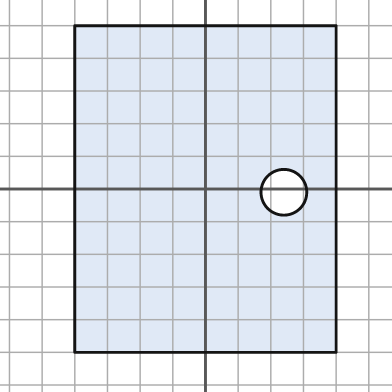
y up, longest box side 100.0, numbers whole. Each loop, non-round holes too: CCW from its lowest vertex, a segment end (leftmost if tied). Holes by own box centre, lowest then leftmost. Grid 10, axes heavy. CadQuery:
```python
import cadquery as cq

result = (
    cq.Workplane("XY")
    .moveTo(-40.0, -50.0)
    .lineTo(40.0, -50.0)
    .lineTo(40.0, 50.0)
    .lineTo(-40.0, 50.0)
    .close()
    .moveTo(24.0, -1.0)
    .circle(7.0)
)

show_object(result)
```